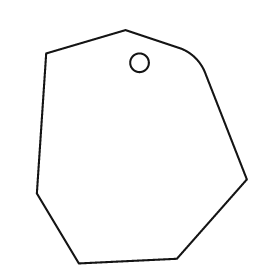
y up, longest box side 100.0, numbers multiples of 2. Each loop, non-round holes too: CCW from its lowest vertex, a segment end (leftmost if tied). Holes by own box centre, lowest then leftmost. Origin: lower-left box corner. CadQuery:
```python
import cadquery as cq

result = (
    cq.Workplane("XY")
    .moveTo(18.0, 0.0)
    .lineTo(60.0, 2.0)
    .lineTo(90.0, 36.0)
    .lineTo(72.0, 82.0)
    .threePointArc((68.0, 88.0), (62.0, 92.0))
    .lineTo(38.0, 100.0)
    .lineTo(4.0, 90.0)
    .lineTo(0.0, 30.0)
    .close()
    .moveTo(44.0, 86.0)
    .circle(4.0)
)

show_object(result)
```